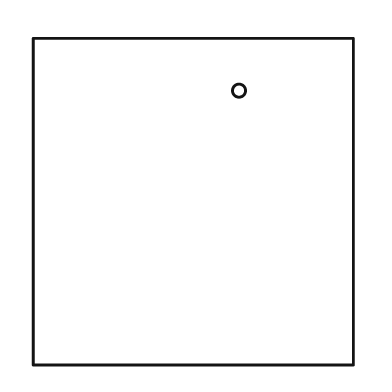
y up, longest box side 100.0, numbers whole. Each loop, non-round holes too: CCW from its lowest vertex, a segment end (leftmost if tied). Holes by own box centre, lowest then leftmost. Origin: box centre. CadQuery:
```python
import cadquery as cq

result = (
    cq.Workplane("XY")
    .moveTo(-49.0, -50.0)
    .lineTo(49.0, -50.0)
    .lineTo(49.0, 50.0)
    .lineTo(-49.0, 50.0)
    .close()
    .moveTo(14.0, 34.0)
    .circle(2.0)
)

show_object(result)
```